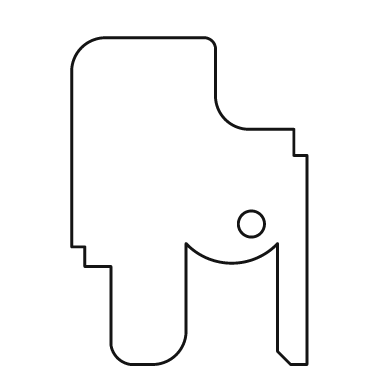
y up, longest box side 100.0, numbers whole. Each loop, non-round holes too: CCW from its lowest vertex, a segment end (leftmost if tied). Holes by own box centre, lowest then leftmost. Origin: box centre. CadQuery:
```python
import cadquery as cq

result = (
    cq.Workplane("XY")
    .moveTo(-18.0, -50.0)
    .lineTo(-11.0, -50.0)
    .threePointArc((-4.0, -47.0), (-1.0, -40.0))
    .lineTo(-1.0, -13.0)
    .threePointArc((13.0, -19.0), (27.0, -13.0))
    .lineTo(27.0, -46.0)
    .lineTo(31.0, -50.0)
    .lineTo(36.0, -50.0)
    .lineTo(36.0, 14.0)
    .lineTo(32.0, 14.0)
    .lineTo(32.0, 22.0)
    .lineTo(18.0, 22.0)
    .threePointArc((11.0, 25.0), (8.0, 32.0))
    .lineTo(8.0, 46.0)
    .threePointArc((7.0, 49.0), (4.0, 50.0))
    .lineTo(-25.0, 50.0)
    .threePointArc((-33.0, 47.0), (-36.0, 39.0))
    .lineTo(-36.0, -14.0)
    .lineTo(-32.0, -14.0)
    .lineTo(-32.0, -20.0)
    .lineTo(-24.0, -20.0)
    .lineTo(-24.0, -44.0)
    .threePointArc((-22.0, -48.0), (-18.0, -50.0))
    .close()
    .moveTo(19.0, -7.0)
    .circle(4.0)
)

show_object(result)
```